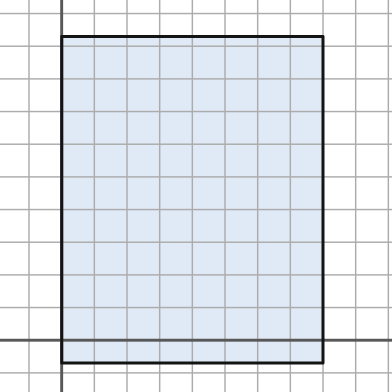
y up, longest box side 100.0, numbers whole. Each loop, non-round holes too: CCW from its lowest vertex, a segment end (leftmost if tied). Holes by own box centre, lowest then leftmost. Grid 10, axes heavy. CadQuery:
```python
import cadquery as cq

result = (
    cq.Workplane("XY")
    .moveTo(0.0, -7.0)
    .lineTo(80.0, -7.0)
    .lineTo(80.0, 93.0)
    .lineTo(0.0, 93.0)
    .close()
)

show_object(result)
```